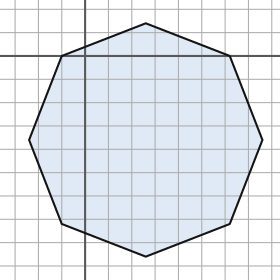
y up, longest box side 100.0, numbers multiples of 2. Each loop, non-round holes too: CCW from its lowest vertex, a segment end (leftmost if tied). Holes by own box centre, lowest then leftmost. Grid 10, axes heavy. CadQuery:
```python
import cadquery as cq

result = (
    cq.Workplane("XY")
    .moveTo(26.0, -86.0)
    .lineTo(62.0, -72.0)
    .lineTo(76.0, -36.0)
    .lineTo(62.0, 0.0)
    .lineTo(26.0, 14.0)
    .lineTo(-10.0, 0.0)
    .lineTo(-24.0, -36.0)
    .lineTo(-10.0, -72.0)
    .close()
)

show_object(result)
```